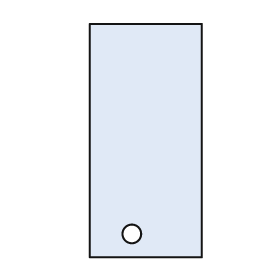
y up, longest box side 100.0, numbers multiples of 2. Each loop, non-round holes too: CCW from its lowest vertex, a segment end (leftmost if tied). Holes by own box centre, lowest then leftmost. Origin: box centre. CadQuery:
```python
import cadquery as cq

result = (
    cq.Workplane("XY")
    .moveTo(-24.0, -50.0)
    .lineTo(24.0, -50.0)
    .lineTo(24.0, 50.0)
    .lineTo(-24.0, 50.0)
    .close()
    .moveTo(-6.0, -40.0)
    .circle(4.0)
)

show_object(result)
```